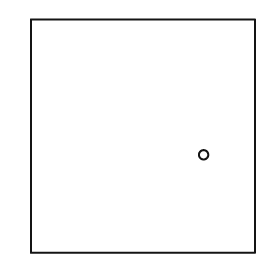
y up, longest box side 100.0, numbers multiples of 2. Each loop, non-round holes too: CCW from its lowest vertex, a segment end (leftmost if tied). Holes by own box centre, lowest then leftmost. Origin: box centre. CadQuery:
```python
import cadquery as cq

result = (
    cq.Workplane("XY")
    .moveTo(-48.0, -50.0)
    .lineTo(48.0, -50.0)
    .lineTo(48.0, 50.0)
    .lineTo(-48.0, 50.0)
    .close()
    .moveTo(26.0, -8.0)
    .circle(2.0)
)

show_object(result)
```